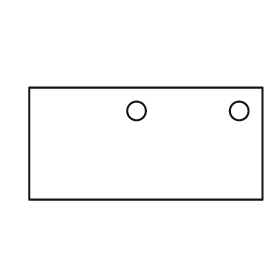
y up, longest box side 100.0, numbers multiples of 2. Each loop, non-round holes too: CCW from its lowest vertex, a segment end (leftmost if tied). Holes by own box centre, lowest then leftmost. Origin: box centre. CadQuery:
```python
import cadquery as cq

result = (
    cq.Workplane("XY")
    .moveTo(-50.0, -24.0)
    .lineTo(50.0, -24.0)
    .lineTo(50.0, 24.0)
    .lineTo(-50.0, 24.0)
    .close()
    .moveTo(-4.0, 14.0)
    .circle(4.0)
    .moveTo(40.0, 14.0)
    .circle(4.0)
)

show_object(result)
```